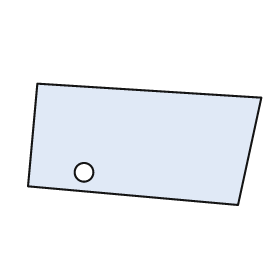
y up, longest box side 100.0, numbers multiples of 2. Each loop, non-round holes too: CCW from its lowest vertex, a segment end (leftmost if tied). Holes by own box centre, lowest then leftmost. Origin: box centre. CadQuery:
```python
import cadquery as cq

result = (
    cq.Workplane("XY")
    .moveTo(40.0, -26.0)
    .lineTo(50.0, 20.0)
    .lineTo(-46.0, 26.0)
    .lineTo(-50.0, -18.0)
    .close()
    .moveTo(-26.0, -12.0)
    .circle(4.0)
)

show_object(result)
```